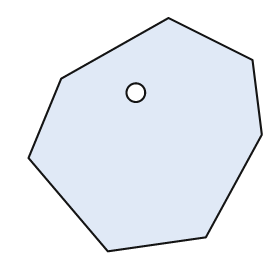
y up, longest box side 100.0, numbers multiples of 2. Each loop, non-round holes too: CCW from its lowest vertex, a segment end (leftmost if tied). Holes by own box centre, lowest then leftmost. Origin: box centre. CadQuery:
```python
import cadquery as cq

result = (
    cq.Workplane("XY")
    .moveTo(-16.0, -50.0)
    .lineTo(26.0, -44.0)
    .lineTo(50.0, 0.0)
    .lineTo(46.0, 32.0)
    .lineTo(10.0, 50.0)
    .lineTo(-36.0, 24.0)
    .lineTo(-50.0, -10.0)
    .close()
    .moveTo(-4.0, 18.0)
    .circle(4.0)
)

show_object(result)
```